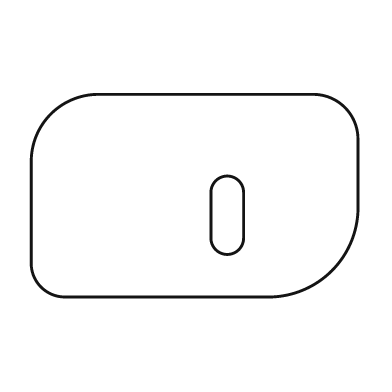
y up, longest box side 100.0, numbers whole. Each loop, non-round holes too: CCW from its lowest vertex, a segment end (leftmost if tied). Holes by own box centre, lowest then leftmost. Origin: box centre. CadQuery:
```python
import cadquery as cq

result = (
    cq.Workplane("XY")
    .moveTo(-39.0, -31.0)
    .lineTo(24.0, -31.0)
    .threePointArc((42.0, -23.0), (50.0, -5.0))
    .lineTo(50.0, 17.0)
    .threePointArc((46.0, 27.0), (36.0, 31.0))
    .lineTo(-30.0, 31.0)
    .threePointArc((-44.0, 25.0), (-50.0, 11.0))
    .lineTo(-50.0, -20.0)
    .threePointArc((-47.0, -28.0), (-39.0, -31.0))
    .close()
    .moveTo(5.0, -13.0)
    .threePointArc((10.0, -18.0), (15.0, -13.0))
    .lineTo(15.0, 1.0)
    .threePointArc((10.0, 6.0), (5.0, 1.0))
    .close()
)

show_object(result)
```